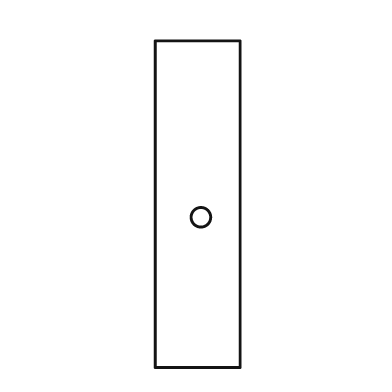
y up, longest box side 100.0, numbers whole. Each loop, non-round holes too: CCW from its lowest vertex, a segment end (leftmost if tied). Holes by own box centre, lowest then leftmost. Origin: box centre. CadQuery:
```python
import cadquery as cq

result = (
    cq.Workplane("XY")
    .moveTo(-13.0, -50.0)
    .lineTo(13.0, -50.0)
    .lineTo(13.0, 50.0)
    .lineTo(-13.0, 50.0)
    .close()
    .moveTo(1.0, -4.0)
    .circle(3.0)
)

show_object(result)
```